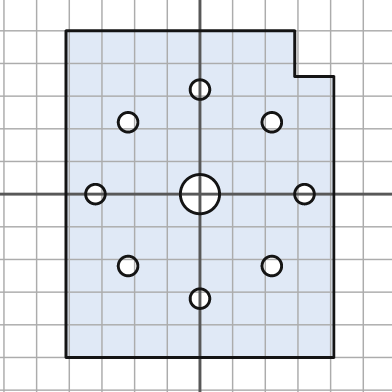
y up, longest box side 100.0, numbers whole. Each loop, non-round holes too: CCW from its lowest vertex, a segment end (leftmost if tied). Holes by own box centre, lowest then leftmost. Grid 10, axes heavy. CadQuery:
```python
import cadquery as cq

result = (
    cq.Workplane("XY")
    .moveTo(-41.0, -50.0)
    .lineTo(41.0, -50.0)
    .lineTo(41.0, 36.0)
    .lineTo(29.0, 36.0)
    .lineTo(29.0, 50.0)
    .lineTo(-41.0, 50.0)
    .close()
    .moveTo(0.0, -32.0)
    .circle(3.0)
    .moveTo(-22.0, -22.0)
    .circle(3.0)
    .moveTo(22.0, -22.0)
    .circle(3.0)
    .moveTo(-32.0, 0.0)
    .circle(3.0)
    .moveTo(0.0, 0.0)
    .circle(6.0)
    .moveTo(32.0, 0.0)
    .circle(3.0)
    .moveTo(-22.0, 22.0)
    .circle(3.0)
    .moveTo(22.0, 22.0)
    .circle(3.0)
    .moveTo(0.0, 32.0)
    .circle(3.0)
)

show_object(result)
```